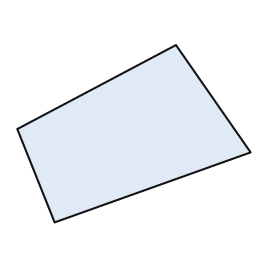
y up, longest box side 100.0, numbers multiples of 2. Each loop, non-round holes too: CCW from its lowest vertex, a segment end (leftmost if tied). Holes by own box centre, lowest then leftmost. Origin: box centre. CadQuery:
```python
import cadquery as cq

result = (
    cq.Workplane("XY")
    .moveTo(-34.0, -38.0)
    .lineTo(50.0, -8.0)
    .lineTo(18.0, 38.0)
    .lineTo(-50.0, 2.0)
    .close()
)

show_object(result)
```